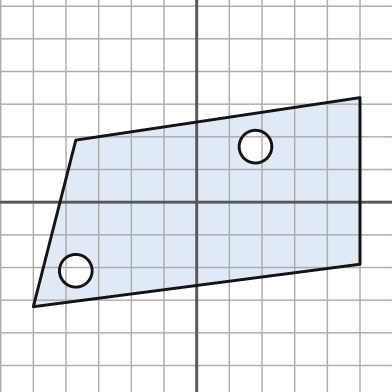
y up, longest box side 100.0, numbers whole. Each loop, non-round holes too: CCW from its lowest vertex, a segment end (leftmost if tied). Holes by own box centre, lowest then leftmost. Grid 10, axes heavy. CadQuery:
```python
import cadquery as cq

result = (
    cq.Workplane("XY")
    .moveTo(-50.0, -32.0)
    .lineTo(50.0, -19.0)
    .lineTo(50.0, 32.0)
    .lineTo(-37.0, 19.0)
    .close()
    .moveTo(-37.0, -21.0)
    .circle(5.0)
    .moveTo(18.0, 17.0)
    .circle(5.0)
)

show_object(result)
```